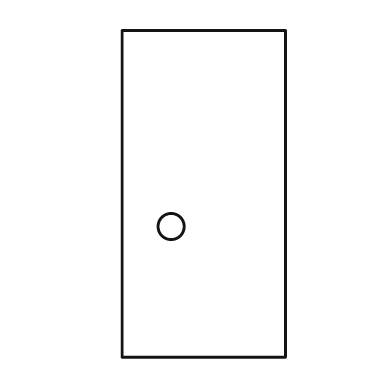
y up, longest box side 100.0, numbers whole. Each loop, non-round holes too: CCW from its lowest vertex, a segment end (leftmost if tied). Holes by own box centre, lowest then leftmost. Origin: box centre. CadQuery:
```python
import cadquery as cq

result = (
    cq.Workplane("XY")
    .moveTo(-25.0, -50.0)
    .lineTo(25.0, -50.0)
    .lineTo(25.0, 50.0)
    .lineTo(-25.0, 50.0)
    .close()
    .moveTo(-10.0, -10.0)
    .circle(4.0)
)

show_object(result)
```